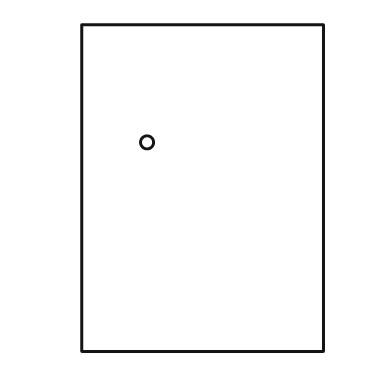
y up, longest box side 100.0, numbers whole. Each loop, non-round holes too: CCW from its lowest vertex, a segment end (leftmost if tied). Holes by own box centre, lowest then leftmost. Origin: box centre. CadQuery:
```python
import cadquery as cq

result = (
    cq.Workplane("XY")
    .moveTo(-37.0, -50.0)
    .lineTo(37.0, -50.0)
    .lineTo(37.0, 50.0)
    .lineTo(-37.0, 50.0)
    .close()
    .moveTo(-17.0, 14.0)
    .circle(2.0)
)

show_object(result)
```